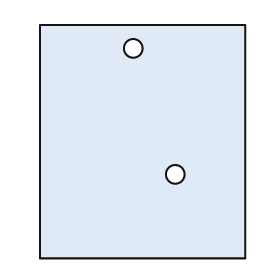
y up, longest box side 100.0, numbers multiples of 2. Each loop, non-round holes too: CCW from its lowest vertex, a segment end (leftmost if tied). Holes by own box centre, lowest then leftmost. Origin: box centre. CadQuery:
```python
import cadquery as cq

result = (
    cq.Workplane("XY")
    .moveTo(-44.0, -50.0)
    .lineTo(44.0, -50.0)
    .lineTo(44.0, 50.0)
    .lineTo(-44.0, 50.0)
    .close()
    .moveTo(14.0, -14.0)
    .circle(4.0)
    .moveTo(-4.0, 40.0)
    .circle(4.0)
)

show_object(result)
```